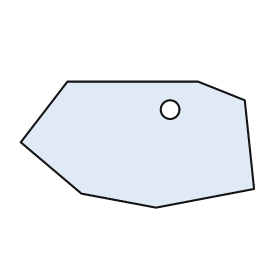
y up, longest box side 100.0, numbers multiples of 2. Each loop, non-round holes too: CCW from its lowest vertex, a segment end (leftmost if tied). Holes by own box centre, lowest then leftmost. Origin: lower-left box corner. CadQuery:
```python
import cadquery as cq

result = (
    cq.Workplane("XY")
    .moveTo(58.0, 0.0)
    .lineTo(100.0, 8.0)
    .lineTo(96.0, 46.0)
    .lineTo(76.0, 54.0)
    .lineTo(20.0, 54.0)
    .lineTo(0.0, 28.0)
    .lineTo(26.0, 6.0)
    .close()
    .moveTo(64.0, 42.0)
    .circle(4.0)
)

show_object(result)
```